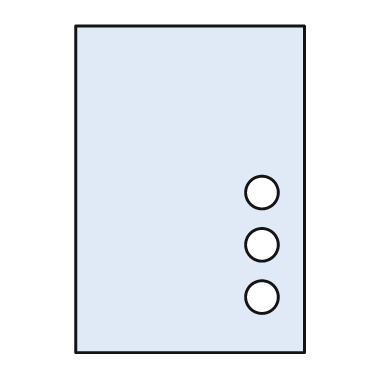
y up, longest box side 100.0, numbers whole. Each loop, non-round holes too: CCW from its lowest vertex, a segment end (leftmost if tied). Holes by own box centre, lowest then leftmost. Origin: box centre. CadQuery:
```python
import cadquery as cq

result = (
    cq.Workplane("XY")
    .moveTo(-35.0, -50.0)
    .lineTo(35.0, -50.0)
    .lineTo(35.0, 50.0)
    .lineTo(-35.0, 50.0)
    .close()
    .moveTo(22.0, -33.0)
    .circle(5.0)
    .moveTo(22.0, -17.0)
    .circle(5.0)
    .moveTo(22.0, -1.0)
    .circle(5.0)
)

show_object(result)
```